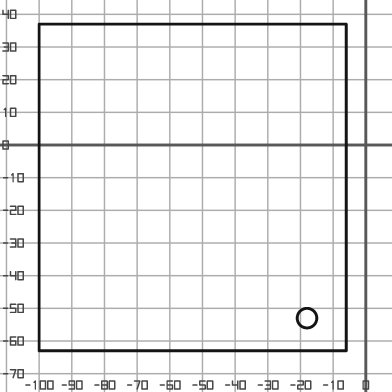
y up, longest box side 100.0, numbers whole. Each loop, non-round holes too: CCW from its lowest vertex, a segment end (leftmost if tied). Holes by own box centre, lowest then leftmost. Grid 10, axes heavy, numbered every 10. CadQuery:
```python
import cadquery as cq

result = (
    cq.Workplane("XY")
    .moveTo(-100.0, -63.0)
    .lineTo(-6.0, -63.0)
    .lineTo(-6.0, 37.0)
    .lineTo(-100.0, 37.0)
    .close()
    .moveTo(-18.0, -53.0)
    .circle(3.0)
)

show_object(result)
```